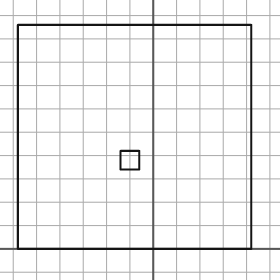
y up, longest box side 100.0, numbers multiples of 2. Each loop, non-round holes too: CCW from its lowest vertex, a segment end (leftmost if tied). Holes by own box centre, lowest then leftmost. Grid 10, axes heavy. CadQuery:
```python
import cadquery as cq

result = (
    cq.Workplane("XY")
    .moveTo(-58.0, 0.0)
    .lineTo(42.0, 0.0)
    .lineTo(42.0, 96.0)
    .lineTo(-58.0, 96.0)
    .close()
    .moveTo(-14.0, 34.0)
    .lineTo(-6.0, 34.0)
    .lineTo(-6.0, 42.0)
    .lineTo(-14.0, 42.0)
    .close()
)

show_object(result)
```